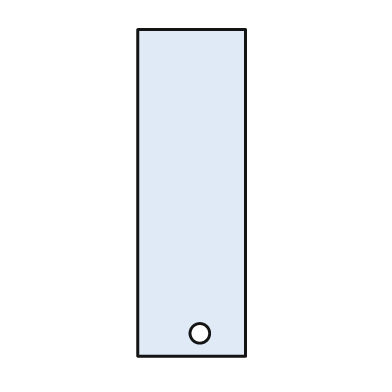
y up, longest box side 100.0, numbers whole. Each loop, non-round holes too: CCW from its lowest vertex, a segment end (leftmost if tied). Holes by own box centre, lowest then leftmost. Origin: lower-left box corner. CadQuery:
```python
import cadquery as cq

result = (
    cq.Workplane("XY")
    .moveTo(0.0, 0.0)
    .lineTo(33.0, 0.0)
    .lineTo(33.0, 100.0)
    .lineTo(0.0, 100.0)
    .close()
    .moveTo(19.0, 7.0)
    .circle(3.0)
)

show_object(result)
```